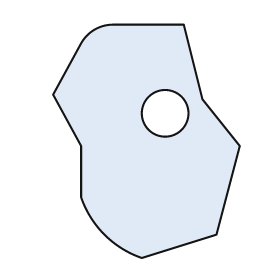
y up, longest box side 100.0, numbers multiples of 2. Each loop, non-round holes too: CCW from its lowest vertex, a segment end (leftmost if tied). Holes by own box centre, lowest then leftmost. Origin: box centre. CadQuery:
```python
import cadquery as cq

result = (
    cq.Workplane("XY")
    .moveTo(-2.0, -50.0)
    .lineTo(30.0, -40.0)
    .lineTo(40.0, -2.0)
    .lineTo(24.0, 18.0)
    .lineTo(16.0, 50.0)
    .lineTo(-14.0, 50.0)
    .threePointArc((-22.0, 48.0), (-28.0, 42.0))
    .lineTo(-40.0, 20.0)
    .lineTo(-28.0, -2.0)
    .lineTo(-28.0, -24.0)
    .threePointArc((-18.0, -40.0), (-2.0, -50.0))
    .close()
    .moveTo(8.0, 12.0)
    .circle(10.0)
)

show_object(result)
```